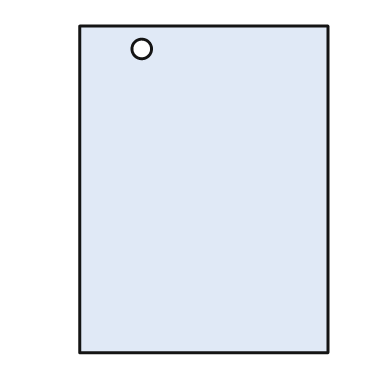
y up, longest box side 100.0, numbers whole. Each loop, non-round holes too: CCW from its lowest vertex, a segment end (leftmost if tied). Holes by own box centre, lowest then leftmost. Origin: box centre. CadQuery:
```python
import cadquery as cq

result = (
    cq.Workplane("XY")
    .moveTo(-38.0, -50.0)
    .lineTo(38.0, -50.0)
    .lineTo(38.0, 50.0)
    .lineTo(-38.0, 50.0)
    .close()
    .moveTo(-19.0, 43.0)
    .circle(3.0)
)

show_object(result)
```